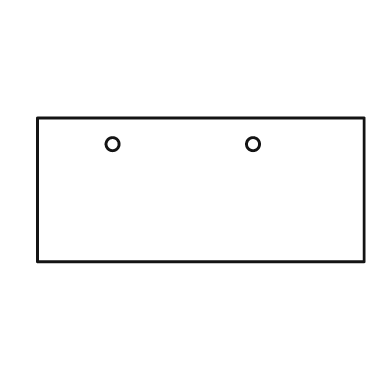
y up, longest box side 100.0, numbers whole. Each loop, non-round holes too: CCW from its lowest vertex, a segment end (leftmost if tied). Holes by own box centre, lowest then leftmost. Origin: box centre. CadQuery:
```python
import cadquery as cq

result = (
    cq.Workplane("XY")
    .moveTo(-50.0, -22.0)
    .lineTo(50.0, -22.0)
    .lineTo(50.0, 22.0)
    .lineTo(-50.0, 22.0)
    .close()
    .moveTo(-27.0, 14.0)
    .circle(2.0)
    .moveTo(16.0, 14.0)
    .circle(2.0)
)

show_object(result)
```